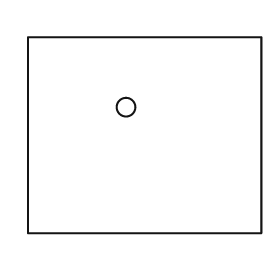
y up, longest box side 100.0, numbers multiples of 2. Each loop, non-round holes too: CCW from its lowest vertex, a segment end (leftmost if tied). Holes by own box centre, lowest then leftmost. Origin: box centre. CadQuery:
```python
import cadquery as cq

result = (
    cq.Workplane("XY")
    .moveTo(-50.0, -42.0)
    .lineTo(50.0, -42.0)
    .lineTo(50.0, 42.0)
    .lineTo(-50.0, 42.0)
    .close()
    .moveTo(-8.0, 12.0)
    .circle(4.0)
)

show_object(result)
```